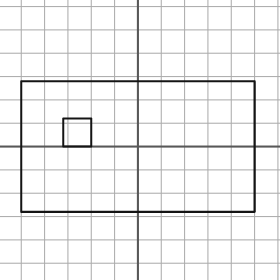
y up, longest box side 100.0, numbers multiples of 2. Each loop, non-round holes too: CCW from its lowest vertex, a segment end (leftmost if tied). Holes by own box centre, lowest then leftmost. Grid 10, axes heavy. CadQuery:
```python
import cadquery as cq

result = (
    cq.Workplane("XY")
    .moveTo(-50.0, -28.0)
    .lineTo(50.0, -28.0)
    .lineTo(50.0, 28.0)
    .lineTo(-50.0, 28.0)
    .close()
    .moveTo(-32.0, 0.0)
    .lineTo(-20.0, 0.0)
    .lineTo(-20.0, 12.0)
    .lineTo(-32.0, 12.0)
    .close()
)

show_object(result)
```